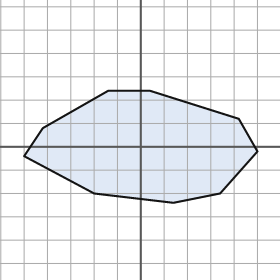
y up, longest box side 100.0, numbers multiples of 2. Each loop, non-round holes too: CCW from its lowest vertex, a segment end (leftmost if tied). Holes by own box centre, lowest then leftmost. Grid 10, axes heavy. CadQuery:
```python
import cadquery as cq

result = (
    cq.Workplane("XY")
    .moveTo(14.0, -24.0)
    .lineTo(34.0, -20.0)
    .lineTo(50.0, -2.0)
    .lineTo(42.0, 12.0)
    .lineTo(4.0, 24.0)
    .lineTo(-14.0, 24.0)
    .lineTo(-42.0, 8.0)
    .lineTo(-50.0, -4.0)
    .lineTo(-20.0, -20.0)
    .close()
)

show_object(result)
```